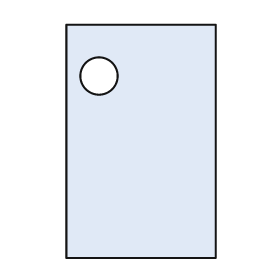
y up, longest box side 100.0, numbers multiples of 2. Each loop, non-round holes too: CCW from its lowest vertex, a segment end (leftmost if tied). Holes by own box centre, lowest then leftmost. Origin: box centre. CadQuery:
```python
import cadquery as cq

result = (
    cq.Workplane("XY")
    .moveTo(-32.0, -50.0)
    .lineTo(32.0, -50.0)
    .lineTo(32.0, 50.0)
    .lineTo(-32.0, 50.0)
    .close()
    .moveTo(-18.0, 28.0)
    .circle(8.0)
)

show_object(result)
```